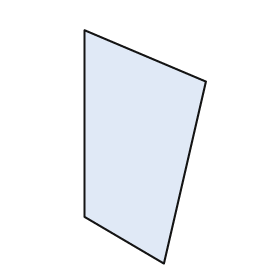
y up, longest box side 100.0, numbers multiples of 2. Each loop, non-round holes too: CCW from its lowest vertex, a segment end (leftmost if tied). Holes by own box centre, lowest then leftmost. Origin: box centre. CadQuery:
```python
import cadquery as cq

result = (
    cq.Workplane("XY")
    .moveTo(8.0, -50.0)
    .lineTo(26.0, 28.0)
    .lineTo(-26.0, 50.0)
    .lineTo(-26.0, -30.0)
    .close()
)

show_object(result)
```